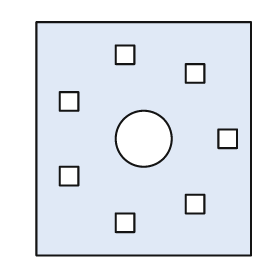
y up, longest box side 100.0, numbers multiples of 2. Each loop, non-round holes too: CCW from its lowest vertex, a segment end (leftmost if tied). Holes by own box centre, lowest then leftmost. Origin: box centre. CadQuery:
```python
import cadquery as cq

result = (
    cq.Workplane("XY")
    .moveTo(-46.0, -50.0)
    .lineTo(46.0, -50.0)
    .lineTo(46.0, 50.0)
    .lineTo(-46.0, 50.0)
    .close()
    .moveTo(-12.0, -40.0)
    .lineTo(-4.0, -40.0)
    .lineTo(-4.0, -32.0)
    .lineTo(-12.0, -32.0)
    .close()
    .moveTo(18.0, -32.0)
    .lineTo(26.0, -32.0)
    .lineTo(26.0, -24.0)
    .lineTo(18.0, -24.0)
    .close()
    .moveTo(-36.0, -20.0)
    .lineTo(-28.0, -20.0)
    .lineTo(-28.0, -12.0)
    .lineTo(-36.0, -12.0)
    .close()
    .moveTo(0.0, 0.0)
    .circle(12.0)
    .moveTo(32.0, -4.0)
    .lineTo(40.0, -4.0)
    .lineTo(40.0, 4.0)
    .lineTo(32.0, 4.0)
    .close()
    .moveTo(-36.0, 12.0)
    .lineTo(-28.0, 12.0)
    .lineTo(-28.0, 20.0)
    .lineTo(-36.0, 20.0)
    .close()
    .moveTo(18.0, 24.0)
    .lineTo(26.0, 24.0)
    .lineTo(26.0, 32.0)
    .lineTo(18.0, 32.0)
    .close()
    .moveTo(-12.0, 32.0)
    .lineTo(-4.0, 32.0)
    .lineTo(-4.0, 40.0)
    .lineTo(-12.0, 40.0)
    .close()
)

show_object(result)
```